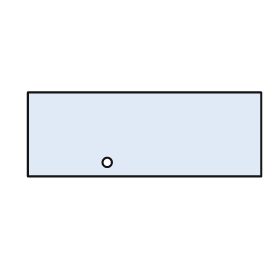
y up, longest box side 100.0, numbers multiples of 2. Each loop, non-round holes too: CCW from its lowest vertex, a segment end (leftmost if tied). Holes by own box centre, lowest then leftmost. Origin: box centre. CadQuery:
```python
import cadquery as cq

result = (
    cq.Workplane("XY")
    .moveTo(-50.0, -18.0)
    .lineTo(50.0, -18.0)
    .lineTo(50.0, 18.0)
    .lineTo(-50.0, 18.0)
    .close()
    .moveTo(-16.0, -12.0)
    .circle(2.0)
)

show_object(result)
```